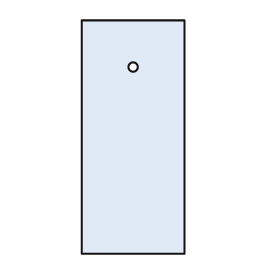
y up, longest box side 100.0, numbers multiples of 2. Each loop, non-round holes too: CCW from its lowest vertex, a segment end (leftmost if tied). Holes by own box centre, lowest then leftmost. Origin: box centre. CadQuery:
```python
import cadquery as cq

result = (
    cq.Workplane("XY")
    .moveTo(-22.0, -50.0)
    .lineTo(22.0, -50.0)
    .lineTo(22.0, 50.0)
    .lineTo(-22.0, 50.0)
    .close()
    .moveTo(0.0, 30.0)
    .circle(2.0)
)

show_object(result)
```